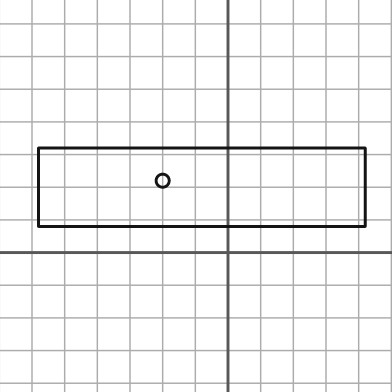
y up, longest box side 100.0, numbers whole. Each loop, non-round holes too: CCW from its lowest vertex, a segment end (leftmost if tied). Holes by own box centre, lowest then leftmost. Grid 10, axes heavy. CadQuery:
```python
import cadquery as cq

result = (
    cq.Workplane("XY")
    .moveTo(-58.0, 8.0)
    .lineTo(42.0, 8.0)
    .lineTo(42.0, 32.0)
    .lineTo(-58.0, 32.0)
    .close()
    .moveTo(-20.0, 22.0)
    .circle(2.0)
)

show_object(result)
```